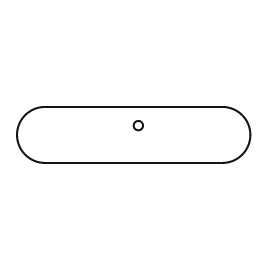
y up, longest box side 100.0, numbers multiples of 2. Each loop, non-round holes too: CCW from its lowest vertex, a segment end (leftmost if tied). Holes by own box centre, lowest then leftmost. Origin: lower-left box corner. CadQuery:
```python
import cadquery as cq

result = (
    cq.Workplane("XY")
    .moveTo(12.0, 0.0)
    .lineTo(88.0, 0.0)
    .threePointArc((100.0, 12.0), (88.0, 24.0))
    .lineTo(12.0, 24.0)
    .threePointArc((0.0, 12.0), (12.0, 0.0))
    .close()
    .moveTo(52.0, 16.0)
    .circle(2.0)
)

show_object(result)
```